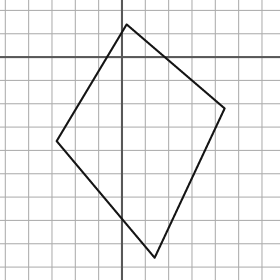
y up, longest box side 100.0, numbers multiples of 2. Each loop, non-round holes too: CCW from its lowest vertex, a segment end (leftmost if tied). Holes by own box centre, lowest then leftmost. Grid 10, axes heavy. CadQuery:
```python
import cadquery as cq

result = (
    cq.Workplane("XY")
    .moveTo(14.0, -86.0)
    .lineTo(44.0, -22.0)
    .lineTo(2.0, 14.0)
    .lineTo(-28.0, -36.0)
    .close()
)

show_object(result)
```